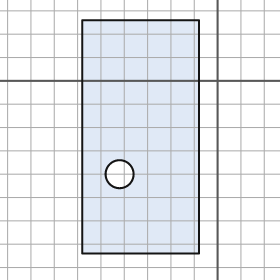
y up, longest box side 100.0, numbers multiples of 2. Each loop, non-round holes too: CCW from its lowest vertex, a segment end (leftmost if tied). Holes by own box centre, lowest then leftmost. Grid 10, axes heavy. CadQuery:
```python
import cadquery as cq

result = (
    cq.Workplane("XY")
    .moveTo(-58.0, -74.0)
    .lineTo(-8.0, -74.0)
    .lineTo(-8.0, 26.0)
    .lineTo(-58.0, 26.0)
    .close()
    .moveTo(-42.0, -40.0)
    .circle(6.0)
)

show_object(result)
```